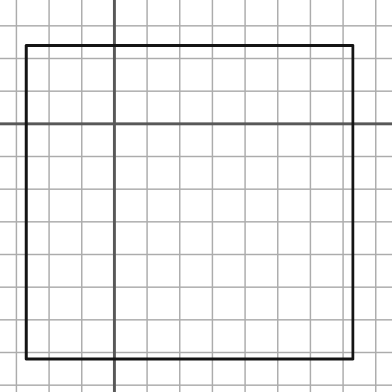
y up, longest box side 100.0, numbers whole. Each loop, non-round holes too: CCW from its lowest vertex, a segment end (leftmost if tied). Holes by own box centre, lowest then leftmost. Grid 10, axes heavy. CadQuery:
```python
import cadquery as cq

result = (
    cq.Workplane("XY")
    .moveTo(-27.0, -72.0)
    .lineTo(73.0, -72.0)
    .lineTo(73.0, 24.0)
    .lineTo(-27.0, 24.0)
    .close()
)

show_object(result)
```